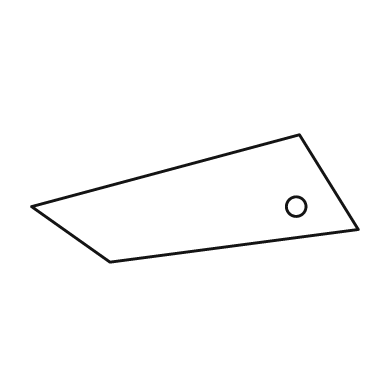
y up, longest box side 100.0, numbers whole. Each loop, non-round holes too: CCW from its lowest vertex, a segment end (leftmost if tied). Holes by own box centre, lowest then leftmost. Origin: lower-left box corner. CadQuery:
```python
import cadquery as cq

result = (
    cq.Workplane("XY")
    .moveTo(24.0, 0.0)
    .lineTo(100.0, 10.0)
    .lineTo(82.0, 39.0)
    .lineTo(0.0, 17.0)
    .close()
    .moveTo(81.0, 17.0)
    .circle(3.0)
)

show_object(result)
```